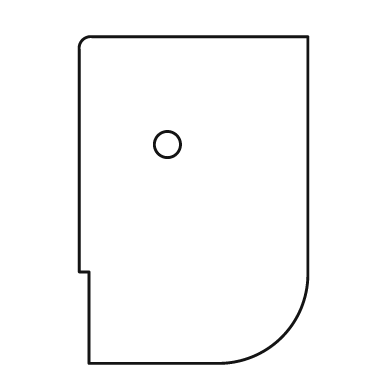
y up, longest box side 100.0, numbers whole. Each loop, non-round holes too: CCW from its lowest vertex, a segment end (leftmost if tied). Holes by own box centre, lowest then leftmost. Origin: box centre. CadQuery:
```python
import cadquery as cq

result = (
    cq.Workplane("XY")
    .moveTo(-32.0, -50.0)
    .lineTo(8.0, -50.0)
    .threePointArc((27.0, -42.0), (35.0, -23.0))
    .lineTo(35.0, 50.0)
    .lineTo(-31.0, 50.0)
    .threePointArc((-34.0, 49.0), (-35.0, 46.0))
    .lineTo(-35.0, -22.0)
    .lineTo(-32.0, -22.0)
    .close()
    .moveTo(-8.0, 17.0)
    .circle(4.0)
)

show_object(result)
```